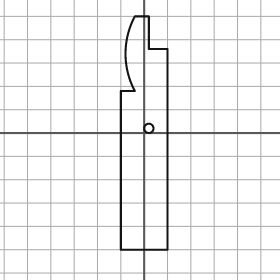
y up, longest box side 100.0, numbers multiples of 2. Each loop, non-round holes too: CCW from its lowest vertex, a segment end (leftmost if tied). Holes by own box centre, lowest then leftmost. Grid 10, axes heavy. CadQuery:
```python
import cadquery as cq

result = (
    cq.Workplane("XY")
    .moveTo(-10.0, -50.0)
    .lineTo(10.0, -50.0)
    .lineTo(10.0, 36.0)
    .lineTo(2.0, 36.0)
    .lineTo(2.0, 50.0)
    .lineTo(-4.0, 50.0)
    .threePointArc((-8.0, 34.0), (-4.0, 18.0))
    .lineTo(-10.0, 18.0)
    .close()
    .moveTo(2.0, 2.0)
    .circle(2.0)
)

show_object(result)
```